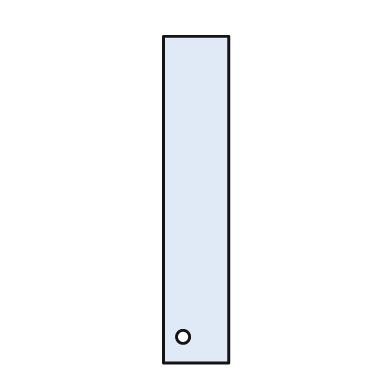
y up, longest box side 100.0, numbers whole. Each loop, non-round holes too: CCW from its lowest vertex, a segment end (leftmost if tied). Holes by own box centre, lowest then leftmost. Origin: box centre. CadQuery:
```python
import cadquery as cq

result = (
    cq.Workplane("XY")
    .moveTo(-10.0, -50.0)
    .lineTo(10.0, -50.0)
    .lineTo(10.0, 50.0)
    .lineTo(-10.0, 50.0)
    .close()
    .moveTo(-4.0, -42.0)
    .circle(2.0)
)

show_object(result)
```